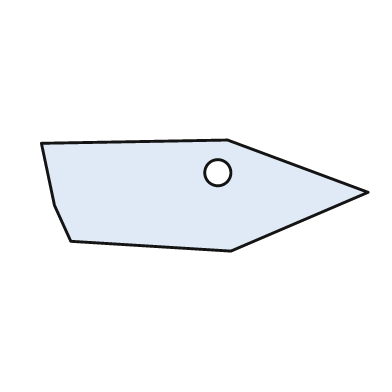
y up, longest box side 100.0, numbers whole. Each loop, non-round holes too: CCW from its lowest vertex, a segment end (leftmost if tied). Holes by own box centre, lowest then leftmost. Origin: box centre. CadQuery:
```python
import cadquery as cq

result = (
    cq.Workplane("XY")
    .moveTo(8.0, -17.0)
    .lineTo(50.0, 1.0)
    .lineTo(7.0, 17.0)
    .lineTo(-50.0, 16.0)
    .lineTo(-46.0, -3.0)
    .lineTo(-41.0, -14.0)
    .close()
    .moveTo(4.0, 7.0)
    .circle(4.0)
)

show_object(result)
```